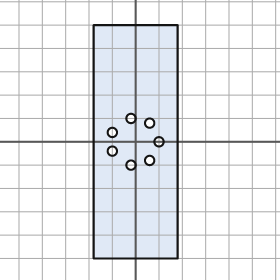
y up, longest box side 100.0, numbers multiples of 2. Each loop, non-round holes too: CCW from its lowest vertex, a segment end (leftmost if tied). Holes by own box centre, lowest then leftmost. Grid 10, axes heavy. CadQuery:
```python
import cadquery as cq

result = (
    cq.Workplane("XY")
    .moveTo(-18.0, -50.0)
    .lineTo(18.0, -50.0)
    .lineTo(18.0, 50.0)
    .lineTo(-18.0, 50.0)
    .close()
    .moveTo(-2.0, -10.0)
    .circle(2.0)
    .moveTo(6.0, -8.0)
    .circle(2.0)
    .moveTo(-10.0, -4.0)
    .circle(2.0)
    .moveTo(10.0, 0.0)
    .circle(2.0)
    .moveTo(-10.0, 4.0)
    .circle(2.0)
    .moveTo(6.0, 8.0)
    .circle(2.0)
    .moveTo(-2.0, 10.0)
    .circle(2.0)
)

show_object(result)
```